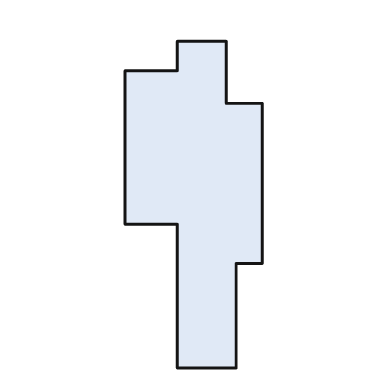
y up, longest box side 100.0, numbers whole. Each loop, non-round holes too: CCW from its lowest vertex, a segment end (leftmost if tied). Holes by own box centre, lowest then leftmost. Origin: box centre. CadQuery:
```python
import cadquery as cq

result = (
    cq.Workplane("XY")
    .moveTo(-5.0, -50.0)
    .lineTo(13.0, -50.0)
    .lineTo(13.0, -18.0)
    .lineTo(21.0, -18.0)
    .lineTo(21.0, 31.0)
    .lineTo(10.0, 31.0)
    .lineTo(10.0, 50.0)
    .lineTo(-5.0, 50.0)
    .lineTo(-5.0, 41.0)
    .lineTo(-21.0, 41.0)
    .lineTo(-21.0, -6.0)
    .lineTo(-5.0, -6.0)
    .close()
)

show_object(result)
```